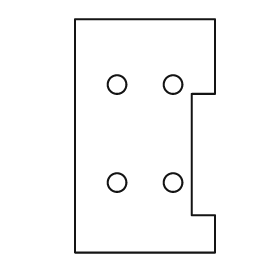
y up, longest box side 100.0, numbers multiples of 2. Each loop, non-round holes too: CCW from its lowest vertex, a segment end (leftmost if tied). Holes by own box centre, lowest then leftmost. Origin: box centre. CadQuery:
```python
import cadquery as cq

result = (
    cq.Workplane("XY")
    .moveTo(-30.0, -50.0)
    .lineTo(30.0, -50.0)
    .lineTo(30.0, -34.0)
    .lineTo(20.0, -34.0)
    .lineTo(20.0, 18.0)
    .lineTo(30.0, 18.0)
    .lineTo(30.0, 50.0)
    .lineTo(-30.0, 50.0)
    .close()
    .moveTo(-12.0, -20.0)
    .circle(4.0)
    .moveTo(12.0, -20.0)
    .circle(4.0)
    .moveTo(-12.0, 22.0)
    .circle(4.0)
    .moveTo(12.0, 22.0)
    .circle(4.0)
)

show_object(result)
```